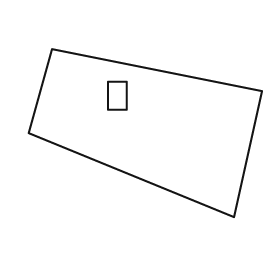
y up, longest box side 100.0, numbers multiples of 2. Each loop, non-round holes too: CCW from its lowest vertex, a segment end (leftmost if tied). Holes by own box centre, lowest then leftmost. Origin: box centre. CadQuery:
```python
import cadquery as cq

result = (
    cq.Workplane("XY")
    .moveTo(38.0, -36.0)
    .lineTo(50.0, 18.0)
    .lineTo(-40.0, 36.0)
    .lineTo(-50.0, 0.0)
    .close()
    .moveTo(-16.0, 10.0)
    .lineTo(-8.0, 10.0)
    .lineTo(-8.0, 22.0)
    .lineTo(-16.0, 22.0)
    .close()
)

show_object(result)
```